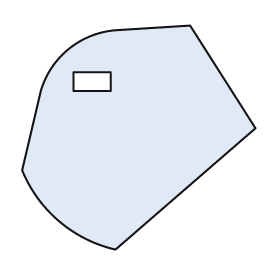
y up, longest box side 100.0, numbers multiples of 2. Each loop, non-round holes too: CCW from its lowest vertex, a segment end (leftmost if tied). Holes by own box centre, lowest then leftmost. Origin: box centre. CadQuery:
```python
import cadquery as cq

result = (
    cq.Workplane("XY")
    .moveTo(-10.0, -48.0)
    .lineTo(50.0, 4.0)
    .lineTo(22.0, 48.0)
    .lineTo(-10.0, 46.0)
    .threePointArc((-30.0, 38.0), (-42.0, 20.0))
    .lineTo(-50.0, -14.0)
    .threePointArc((-34.0, -36.0), (-10.0, -48.0))
    .close()
    .moveTo(-28.0, 20.0)
    .lineTo(-12.0, 20.0)
    .lineTo(-12.0, 28.0)
    .lineTo(-28.0, 28.0)
    .close()
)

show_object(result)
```